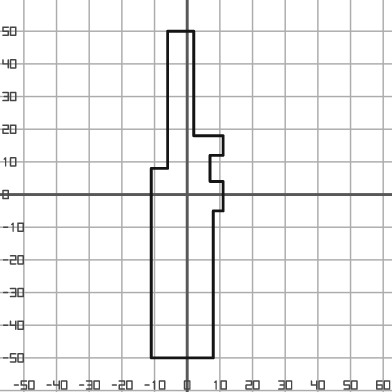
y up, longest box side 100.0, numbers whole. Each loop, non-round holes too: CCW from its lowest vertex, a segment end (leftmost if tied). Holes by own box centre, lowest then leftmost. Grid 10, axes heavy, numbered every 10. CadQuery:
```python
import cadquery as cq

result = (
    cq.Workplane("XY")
    .moveTo(-11.0, -50.0)
    .lineTo(8.0, -50.0)
    .lineTo(8.0, -5.0)
    .lineTo(11.0, -5.0)
    .lineTo(11.0, 4.0)
    .lineTo(7.0, 4.0)
    .lineTo(7.0, 12.0)
    .lineTo(11.0, 12.0)
    .lineTo(11.0, 18.0)
    .lineTo(2.0, 18.0)
    .lineTo(2.0, 50.0)
    .lineTo(-6.0, 50.0)
    .lineTo(-6.0, 8.0)
    .lineTo(-11.0, 8.0)
    .close()
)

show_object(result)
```